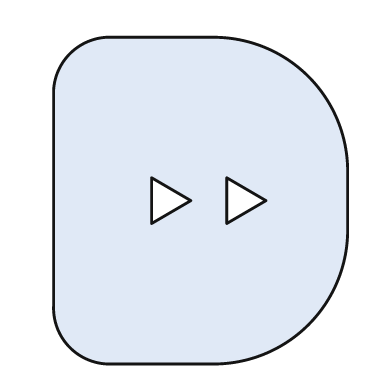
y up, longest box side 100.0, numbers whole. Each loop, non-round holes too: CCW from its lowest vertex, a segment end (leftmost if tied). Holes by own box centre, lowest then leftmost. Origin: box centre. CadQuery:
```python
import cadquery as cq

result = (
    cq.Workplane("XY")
    .moveTo(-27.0, -50.0)
    .lineTo(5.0, -50.0)
    .threePointArc((33.0, -38.0), (45.0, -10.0))
    .lineTo(45.0, 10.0)
    .threePointArc((33.0, 38.0), (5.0, 50.0))
    .lineTo(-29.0, 50.0)
    .threePointArc((-40.0, 45.0), (-45.0, 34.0))
    .lineTo(-45.0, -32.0)
    .threePointArc((-40.0, -45.0), (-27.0, -50.0))
    .close()
    .moveTo(-15.0, -7.0)
    .lineTo(-3.0, 0.0)
    .lineTo(-15.0, 7.0)
    .close()
    .moveTo(8.0, -7.0)
    .lineTo(20.0, 0.0)
    .lineTo(8.0, 7.0)
    .close()
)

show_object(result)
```